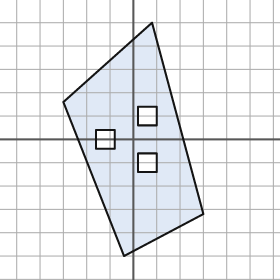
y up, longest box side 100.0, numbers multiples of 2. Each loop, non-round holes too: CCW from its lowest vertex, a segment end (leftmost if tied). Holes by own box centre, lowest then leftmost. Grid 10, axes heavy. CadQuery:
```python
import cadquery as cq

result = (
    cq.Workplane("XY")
    .moveTo(-4.0, -50.0)
    .lineTo(30.0, -32.0)
    .lineTo(8.0, 50.0)
    .lineTo(-30.0, 16.0)
    .close()
    .moveTo(2.0, -14.0)
    .lineTo(10.0, -14.0)
    .lineTo(10.0, -6.0)
    .lineTo(2.0, -6.0)
    .close()
    .moveTo(-16.0, -4.0)
    .lineTo(-8.0, -4.0)
    .lineTo(-8.0, 4.0)
    .lineTo(-16.0, 4.0)
    .close()
    .moveTo(2.0, 6.0)
    .lineTo(10.0, 6.0)
    .lineTo(10.0, 14.0)
    .lineTo(2.0, 14.0)
    .close()
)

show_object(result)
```